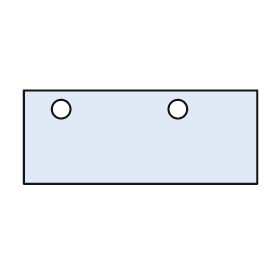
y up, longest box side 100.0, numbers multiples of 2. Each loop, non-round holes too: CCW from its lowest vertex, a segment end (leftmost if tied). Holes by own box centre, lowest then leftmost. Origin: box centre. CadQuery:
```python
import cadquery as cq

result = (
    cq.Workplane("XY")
    .moveTo(-50.0, -20.0)
    .lineTo(50.0, -20.0)
    .lineTo(50.0, 20.0)
    .lineTo(-50.0, 20.0)
    .close()
    .moveTo(-34.0, 12.0)
    .circle(4.0)
    .moveTo(16.0, 12.0)
    .circle(4.0)
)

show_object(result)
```